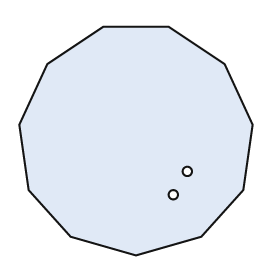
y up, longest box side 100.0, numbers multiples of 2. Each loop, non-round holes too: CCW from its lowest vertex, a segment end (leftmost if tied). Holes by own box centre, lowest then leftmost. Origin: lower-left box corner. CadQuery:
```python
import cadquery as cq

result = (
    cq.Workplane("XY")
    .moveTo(50.0, 0.0)
    .lineTo(78.0, 8.0)
    .lineTo(96.0, 28.0)
    .lineTo(100.0, 56.0)
    .lineTo(88.0, 82.0)
    .lineTo(64.0, 98.0)
    .lineTo(36.0, 98.0)
    .lineTo(12.0, 82.0)
    .lineTo(0.0, 56.0)
    .lineTo(4.0, 28.0)
    .lineTo(22.0, 8.0)
    .close()
    .moveTo(66.0, 26.0)
    .circle(2.0)
    .moveTo(72.0, 36.0)
    .circle(2.0)
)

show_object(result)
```